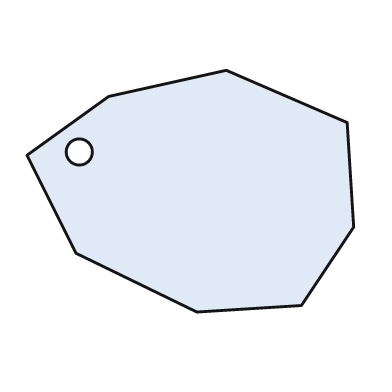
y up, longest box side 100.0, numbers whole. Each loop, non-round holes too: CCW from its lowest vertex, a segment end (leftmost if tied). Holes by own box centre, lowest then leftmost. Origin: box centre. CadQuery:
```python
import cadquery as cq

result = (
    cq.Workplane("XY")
    .moveTo(2.0, -37.0)
    .lineTo(34.0, -35.0)
    .lineTo(50.0, -11.0)
    .lineTo(48.0, 21.0)
    .lineTo(11.0, 37.0)
    .lineTo(-25.0, 29.0)
    .lineTo(-50.0, 11.0)
    .lineTo(-35.0, -19.0)
    .close()
    .moveTo(-34.0, 12.0)
    .circle(4.0)
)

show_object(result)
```